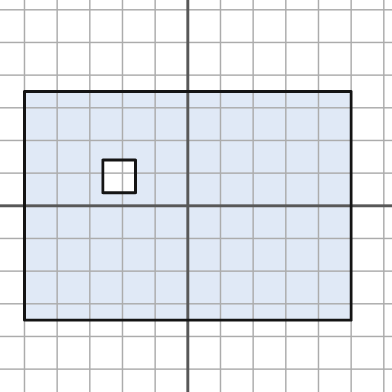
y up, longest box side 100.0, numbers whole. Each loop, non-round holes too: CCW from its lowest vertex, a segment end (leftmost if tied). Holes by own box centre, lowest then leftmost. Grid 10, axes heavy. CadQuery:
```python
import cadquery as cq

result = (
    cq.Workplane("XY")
    .moveTo(-50.0, -35.0)
    .lineTo(50.0, -35.0)
    .lineTo(50.0, 35.0)
    .lineTo(-50.0, 35.0)
    .close()
    .moveTo(-26.0, 4.0)
    .lineTo(-16.0, 4.0)
    .lineTo(-16.0, 14.0)
    .lineTo(-26.0, 14.0)
    .close()
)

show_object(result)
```